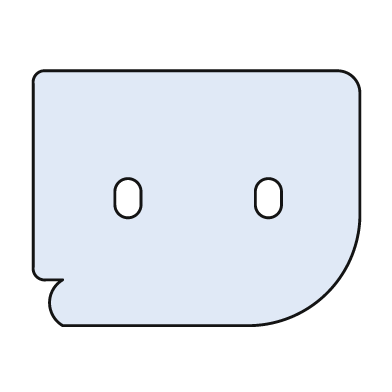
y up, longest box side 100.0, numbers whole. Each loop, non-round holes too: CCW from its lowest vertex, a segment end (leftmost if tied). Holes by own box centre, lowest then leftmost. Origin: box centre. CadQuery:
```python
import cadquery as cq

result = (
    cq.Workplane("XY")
    .moveTo(-41.0, -39.0)
    .lineTo(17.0, -39.0)
    .threePointArc((40.0, -29.0), (50.0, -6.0))
    .lineTo(50.0, 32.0)
    .threePointArc((48.0, 37.0), (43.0, 39.0))
    .lineTo(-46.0, 39.0)
    .threePointArc((-49.0, 38.0), (-50.0, 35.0))
    .lineTo(-50.0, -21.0)
    .threePointArc((-49.0, -24.0), (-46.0, -25.0))
    .lineTo(-41.0, -25.0)
    .threePointArc((-45.0, -32.0), (-41.0, -39.0))
    .close()
    .moveTo(-25.0, -2.0)
    .threePointArc((-21.0, -6.0), (-17.0, -2.0))
    .lineTo(-17.0, 2.0)
    .threePointArc((-21.0, 6.0), (-25.0, 2.0))
    .close()
    .moveTo(18.0, -2.0)
    .threePointArc((22.0, -6.0), (26.0, -2.0))
    .lineTo(26.0, 2.0)
    .threePointArc((22.0, 6.0), (18.0, 2.0))
    .close()
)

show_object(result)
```